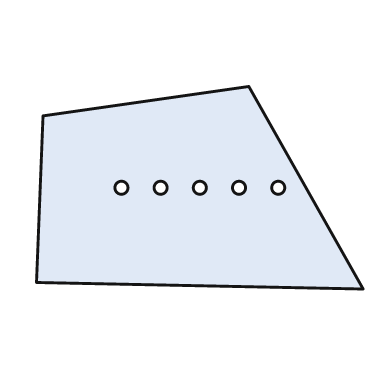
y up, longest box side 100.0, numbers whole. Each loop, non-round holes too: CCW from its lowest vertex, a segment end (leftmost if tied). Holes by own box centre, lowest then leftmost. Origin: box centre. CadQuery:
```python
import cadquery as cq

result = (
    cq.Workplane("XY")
    .moveTo(50.0, -31.0)
    .lineTo(15.0, 31.0)
    .lineTo(-48.0, 22.0)
    .lineTo(-50.0, -29.0)
    .close()
    .moveTo(-24.0, 0.0)
    .circle(2.0)
    .moveTo(-12.0, 0.0)
    .circle(2.0)
    .moveTo(0.0, 0.0)
    .circle(2.0)
    .moveTo(12.0, 0.0)
    .circle(2.0)
    .moveTo(24.0, 0.0)
    .circle(2.0)
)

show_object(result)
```